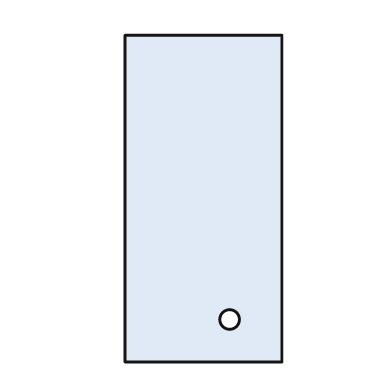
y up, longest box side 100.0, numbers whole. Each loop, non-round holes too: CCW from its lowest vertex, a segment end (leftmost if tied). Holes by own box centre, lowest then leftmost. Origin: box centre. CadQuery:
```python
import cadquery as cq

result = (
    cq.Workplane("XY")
    .moveTo(-24.0, -50.0)
    .lineTo(24.0, -50.0)
    .lineTo(24.0, 50.0)
    .lineTo(-24.0, 50.0)
    .close()
    .moveTo(8.0, -37.0)
    .circle(3.0)
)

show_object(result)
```